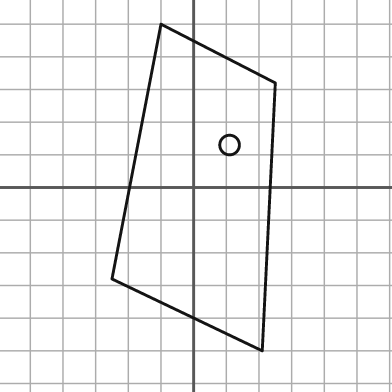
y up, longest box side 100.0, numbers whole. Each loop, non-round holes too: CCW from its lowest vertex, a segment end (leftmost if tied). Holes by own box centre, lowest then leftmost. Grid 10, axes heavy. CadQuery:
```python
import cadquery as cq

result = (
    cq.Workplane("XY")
    .moveTo(21.0, -50.0)
    .lineTo(25.0, 32.0)
    .lineTo(-10.0, 50.0)
    .lineTo(-25.0, -28.0)
    .close()
    .moveTo(11.0, 13.0)
    .circle(3.0)
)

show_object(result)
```